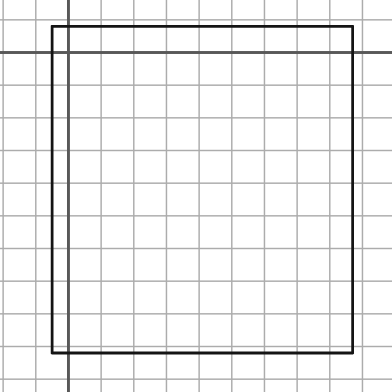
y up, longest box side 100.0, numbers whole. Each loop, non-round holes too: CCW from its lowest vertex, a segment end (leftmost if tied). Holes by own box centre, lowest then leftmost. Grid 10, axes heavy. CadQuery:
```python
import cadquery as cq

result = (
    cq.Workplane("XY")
    .moveTo(-5.0, -92.0)
    .lineTo(87.0, -92.0)
    .lineTo(87.0, 8.0)
    .lineTo(-5.0, 8.0)
    .close()
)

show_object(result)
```